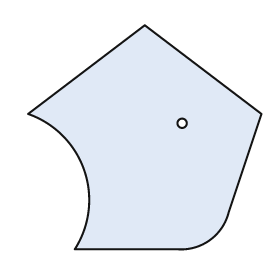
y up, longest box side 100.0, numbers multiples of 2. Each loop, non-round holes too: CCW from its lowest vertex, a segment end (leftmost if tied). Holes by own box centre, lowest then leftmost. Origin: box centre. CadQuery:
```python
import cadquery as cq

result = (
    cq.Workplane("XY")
    .moveTo(-30.0, -48.0)
    .lineTo(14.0, -48.0)
    .threePointArc((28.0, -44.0), (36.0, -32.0))
    .lineTo(50.0, 10.0)
    .lineTo(0.0, 48.0)
    .lineTo(-50.0, 10.0)
    .threePointArc((-26.0, -14.0), (-30.0, -48.0))
    .close()
    .moveTo(16.0, 6.0)
    .circle(2.0)
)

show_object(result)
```